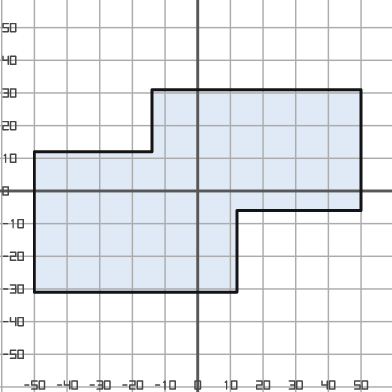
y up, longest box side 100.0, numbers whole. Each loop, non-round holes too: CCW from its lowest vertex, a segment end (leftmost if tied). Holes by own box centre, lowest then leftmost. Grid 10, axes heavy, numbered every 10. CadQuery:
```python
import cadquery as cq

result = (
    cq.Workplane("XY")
    .moveTo(-50.0, -31.0)
    .lineTo(12.0, -31.0)
    .lineTo(12.0, -6.0)
    .lineTo(50.0, -6.0)
    .lineTo(50.0, 31.0)
    .lineTo(-14.0, 31.0)
    .lineTo(-14.0, 12.0)
    .lineTo(-50.0, 12.0)
    .close()
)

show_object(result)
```